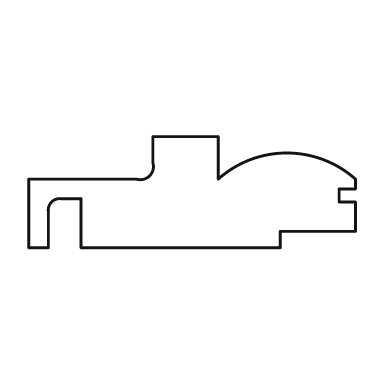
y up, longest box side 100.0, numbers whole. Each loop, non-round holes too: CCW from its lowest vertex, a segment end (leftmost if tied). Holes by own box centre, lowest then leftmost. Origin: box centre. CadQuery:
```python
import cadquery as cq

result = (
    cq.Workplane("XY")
    .moveTo(-50.0, -17.0)
    .lineTo(-44.0, -17.0)
    .lineTo(-44.0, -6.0)
    .threePointArc((-43.0, -3.0), (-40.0, -2.0))
    .lineTo(-34.0, -2.0)
    .lineTo(-34.0, -17.0)
    .lineTo(27.0, -17.0)
    .lineTo(27.0, -12.0)
    .lineTo(50.0, -12.0)
    .lineTo(50.0, -3.0)
    .lineTo(45.0, -3.0)
    .lineTo(45.0, 1.0)
    .lineTo(50.0, 1.0)
    .lineTo(50.0, 4.0)
    .threePointArc((29.0, 12.0), (8.0, 4.0))
    .lineTo(8.0, 17.0)
    .lineTo(-12.0, 17.0)
    .lineTo(-12.0, 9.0)
    .threePointArc((-13.0, 5.0), (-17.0, 4.0))
    .lineTo(-50.0, 4.0)
    .close()
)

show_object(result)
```